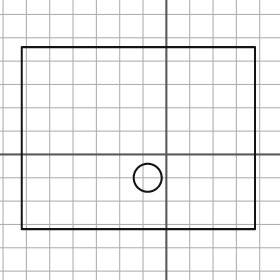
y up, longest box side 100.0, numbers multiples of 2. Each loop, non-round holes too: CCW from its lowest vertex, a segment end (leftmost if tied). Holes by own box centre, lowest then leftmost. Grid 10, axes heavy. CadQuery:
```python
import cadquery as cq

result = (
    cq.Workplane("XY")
    .moveTo(-62.0, -32.0)
    .lineTo(38.0, -32.0)
    .lineTo(38.0, 46.0)
    .lineTo(-62.0, 46.0)
    .close()
    .moveTo(-8.0, -10.0)
    .circle(6.0)
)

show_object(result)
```